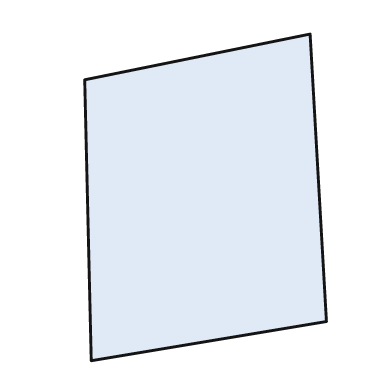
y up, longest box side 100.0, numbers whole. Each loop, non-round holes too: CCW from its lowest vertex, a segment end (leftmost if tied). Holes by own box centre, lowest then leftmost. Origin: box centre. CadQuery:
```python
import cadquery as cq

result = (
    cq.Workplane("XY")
    .moveTo(-35.0, -50.0)
    .lineTo(37.0, -38.0)
    .lineTo(32.0, 50.0)
    .lineTo(-37.0, 36.0)
    .close()
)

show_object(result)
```